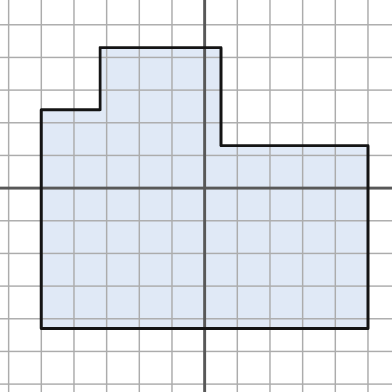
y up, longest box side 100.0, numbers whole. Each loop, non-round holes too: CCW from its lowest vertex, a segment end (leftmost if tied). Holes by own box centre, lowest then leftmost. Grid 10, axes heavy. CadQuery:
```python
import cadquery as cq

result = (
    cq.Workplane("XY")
    .moveTo(-50.0, -43.0)
    .lineTo(50.0, -43.0)
    .lineTo(50.0, 13.0)
    .lineTo(5.0, 13.0)
    .lineTo(5.0, 43.0)
    .lineTo(-32.0, 43.0)
    .lineTo(-32.0, 24.0)
    .lineTo(-50.0, 24.0)
    .close()
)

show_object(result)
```